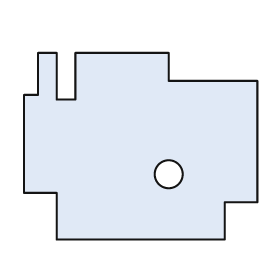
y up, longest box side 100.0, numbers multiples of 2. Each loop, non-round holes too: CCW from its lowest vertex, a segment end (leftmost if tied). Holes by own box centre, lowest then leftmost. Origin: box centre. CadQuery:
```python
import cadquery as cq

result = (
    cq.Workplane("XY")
    .moveTo(-36.0, -40.0)
    .lineTo(36.0, -40.0)
    .lineTo(36.0, -24.0)
    .lineTo(50.0, -24.0)
    .lineTo(50.0, 28.0)
    .lineTo(12.0, 28.0)
    .lineTo(12.0, 40.0)
    .lineTo(-28.0, 40.0)
    .lineTo(-28.0, 20.0)
    .lineTo(-36.0, 20.0)
    .lineTo(-36.0, 40.0)
    .lineTo(-44.0, 40.0)
    .lineTo(-44.0, 22.0)
    .lineTo(-50.0, 22.0)
    .lineTo(-50.0, -20.0)
    .lineTo(-36.0, -20.0)
    .close()
    .moveTo(12.0, -12.0)
    .circle(6.0)
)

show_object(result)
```